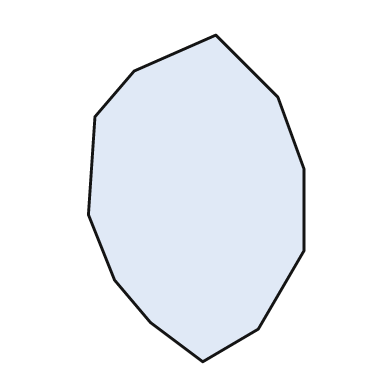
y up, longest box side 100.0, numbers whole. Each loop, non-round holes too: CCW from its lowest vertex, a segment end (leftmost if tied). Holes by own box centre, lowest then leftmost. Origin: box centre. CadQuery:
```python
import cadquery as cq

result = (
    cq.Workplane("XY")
    .moveTo(2.0, -50.0)
    .lineTo(19.0, -40.0)
    .lineTo(33.0, -16.0)
    .lineTo(33.0, 9.0)
    .lineTo(25.0, 31.0)
    .lineTo(6.0, 50.0)
    .lineTo(-19.0, 39.0)
    .lineTo(-31.0, 25.0)
    .lineTo(-33.0, -5.0)
    .lineTo(-25.0, -25.0)
    .lineTo(-14.0, -38.0)
    .close()
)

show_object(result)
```